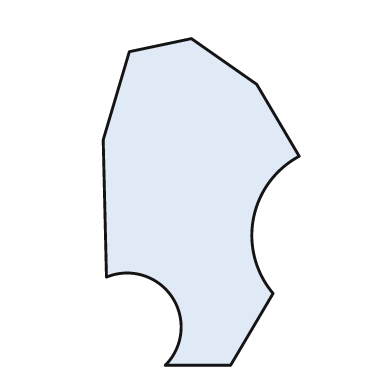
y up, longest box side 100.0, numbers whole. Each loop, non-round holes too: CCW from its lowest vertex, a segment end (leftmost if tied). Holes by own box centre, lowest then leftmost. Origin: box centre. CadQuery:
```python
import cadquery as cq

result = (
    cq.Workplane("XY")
    .moveTo(-11.0, -50.0)
    .lineTo(9.0, -50.0)
    .lineTo(22.0, -28.0)
    .threePointArc((16.0, -5.0), (30.0, 14.0))
    .lineTo(17.0, 36.0)
    .lineTo(-3.0, 50.0)
    .lineTo(-22.0, 46.0)
    .lineTo(-30.0, 19.0)
    .lineTo(-29.0, -23.0)
    .threePointArc((-9.0, -29.0), (-11.0, -50.0))
    .close()
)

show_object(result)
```